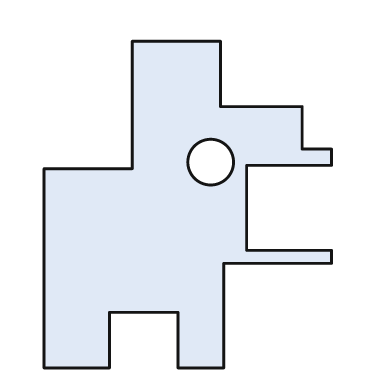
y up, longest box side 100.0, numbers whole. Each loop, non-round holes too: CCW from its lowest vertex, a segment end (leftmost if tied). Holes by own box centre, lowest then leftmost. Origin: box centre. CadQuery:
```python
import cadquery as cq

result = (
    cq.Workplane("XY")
    .moveTo(-44.0, -50.0)
    .lineTo(-24.0, -50.0)
    .lineTo(-24.0, -33.0)
    .lineTo(-3.0, -33.0)
    .lineTo(-3.0, -50.0)
    .lineTo(11.0, -50.0)
    .lineTo(11.0, -18.0)
    .lineTo(44.0, -18.0)
    .lineTo(44.0, -14.0)
    .lineTo(18.0, -14.0)
    .lineTo(18.0, 12.0)
    .lineTo(44.0, 12.0)
    .lineTo(44.0, 17.0)
    .lineTo(35.0, 17.0)
    .lineTo(35.0, 30.0)
    .lineTo(10.0, 30.0)
    .lineTo(10.0, 50.0)
    .lineTo(-17.0, 50.0)
    .lineTo(-17.0, 11.0)
    .lineTo(-44.0, 11.0)
    .close()
    .moveTo(7.0, 13.0)
    .circle(7.0)
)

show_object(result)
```